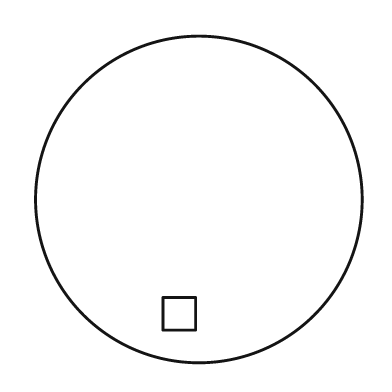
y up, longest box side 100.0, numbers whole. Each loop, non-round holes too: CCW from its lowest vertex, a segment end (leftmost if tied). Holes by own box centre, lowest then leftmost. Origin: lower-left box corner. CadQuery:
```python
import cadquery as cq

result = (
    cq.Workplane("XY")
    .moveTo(50.0, 50.0)
    .circle(50.0)
    .moveTo(39.0, 10.0)
    .lineTo(49.0, 10.0)
    .lineTo(49.0, 20.0)
    .lineTo(39.0, 20.0)
    .close()
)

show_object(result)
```